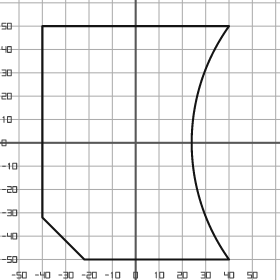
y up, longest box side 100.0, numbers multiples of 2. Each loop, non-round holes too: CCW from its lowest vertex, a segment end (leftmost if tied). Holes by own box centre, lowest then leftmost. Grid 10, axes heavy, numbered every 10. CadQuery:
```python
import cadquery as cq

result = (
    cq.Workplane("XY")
    .moveTo(-22.0, -50.0)
    .lineTo(40.0, -50.0)
    .threePointArc((24.0, 0.0), (40.0, 50.0))
    .lineTo(-40.0, 50.0)
    .lineTo(-40.0, -32.0)
    .close()
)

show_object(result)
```